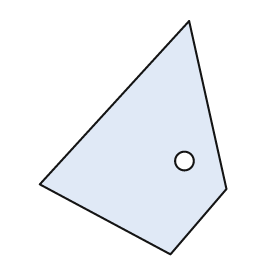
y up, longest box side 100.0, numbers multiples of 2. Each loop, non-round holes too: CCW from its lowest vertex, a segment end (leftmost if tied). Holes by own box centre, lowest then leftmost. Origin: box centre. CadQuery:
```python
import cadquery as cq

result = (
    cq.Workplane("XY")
    .moveTo(16.0, -50.0)
    .lineTo(40.0, -22.0)
    .lineTo(24.0, 50.0)
    .lineTo(-40.0, -20.0)
    .close()
    .moveTo(22.0, -10.0)
    .circle(4.0)
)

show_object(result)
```